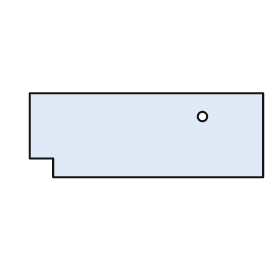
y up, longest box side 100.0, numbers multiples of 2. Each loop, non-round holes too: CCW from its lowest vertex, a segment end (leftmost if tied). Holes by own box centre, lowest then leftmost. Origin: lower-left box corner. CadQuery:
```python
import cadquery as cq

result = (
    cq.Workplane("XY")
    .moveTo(10.0, 0.0)
    .lineTo(100.0, 0.0)
    .lineTo(100.0, 36.0)
    .lineTo(0.0, 36.0)
    .lineTo(0.0, 8.0)
    .lineTo(10.0, 8.0)
    .close()
    .moveTo(74.0, 26.0)
    .circle(2.0)
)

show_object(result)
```